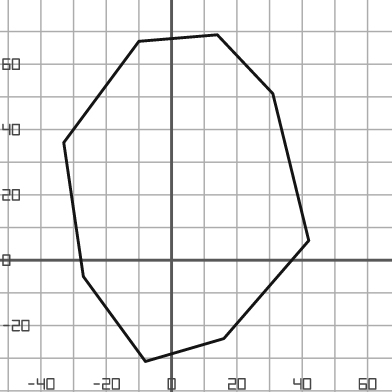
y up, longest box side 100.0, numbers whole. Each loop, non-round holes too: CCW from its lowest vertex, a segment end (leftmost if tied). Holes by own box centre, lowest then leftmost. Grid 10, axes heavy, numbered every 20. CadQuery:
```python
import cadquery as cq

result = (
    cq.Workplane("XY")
    .moveTo(-8.0, -31.0)
    .lineTo(16.0, -24.0)
    .lineTo(42.0, 6.0)
    .lineTo(31.0, 51.0)
    .lineTo(14.0, 69.0)
    .lineTo(-10.0, 67.0)
    .lineTo(-33.0, 36.0)
    .lineTo(-27.0, -5.0)
    .close()
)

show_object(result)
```